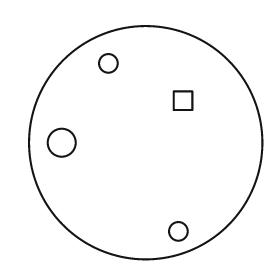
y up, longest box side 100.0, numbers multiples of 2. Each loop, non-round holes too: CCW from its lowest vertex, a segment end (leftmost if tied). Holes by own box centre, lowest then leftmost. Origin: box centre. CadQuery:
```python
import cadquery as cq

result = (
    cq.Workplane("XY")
    .moveTo(0.0, 0.0)
    .circle(50.0)
    .moveTo(14.0, -38.0)
    .circle(4.0)
    .moveTo(-36.0, 0.0)
    .circle(6.0)
    .moveTo(12.0, 14.0)
    .lineTo(20.0, 14.0)
    .lineTo(20.0, 22.0)
    .lineTo(12.0, 22.0)
    .close()
    .moveTo(-16.0, 34.0)
    .circle(4.0)
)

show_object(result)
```